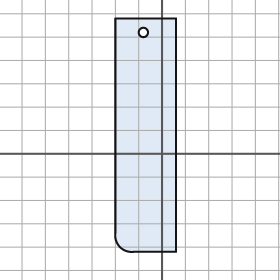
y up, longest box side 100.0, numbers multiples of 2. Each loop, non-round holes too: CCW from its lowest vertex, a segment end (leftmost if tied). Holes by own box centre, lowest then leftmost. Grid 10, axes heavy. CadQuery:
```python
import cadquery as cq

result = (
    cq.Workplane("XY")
    .moveTo(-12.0, -42.0)
    .lineTo(6.0, -42.0)
    .lineTo(6.0, 58.0)
    .lineTo(-20.0, 58.0)
    .lineTo(-20.0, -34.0)
    .threePointArc((-18.0, -40.0), (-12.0, -42.0))
    .close()
    .moveTo(-8.0, 52.0)
    .circle(2.0)
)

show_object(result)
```